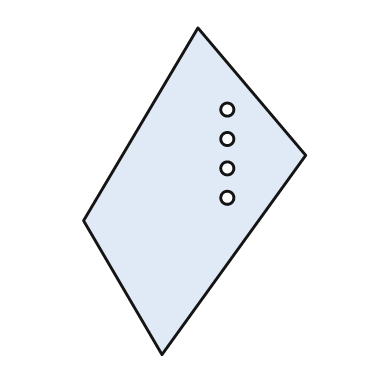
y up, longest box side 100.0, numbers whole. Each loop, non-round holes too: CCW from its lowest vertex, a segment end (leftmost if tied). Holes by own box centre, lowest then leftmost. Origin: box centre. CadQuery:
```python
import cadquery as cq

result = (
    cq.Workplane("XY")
    .moveTo(-10.0, -50.0)
    .lineTo(34.0, 11.0)
    .lineTo(1.0, 50.0)
    .lineTo(-34.0, -9.0)
    .close()
    .moveTo(10.0, -2.0)
    .circle(2.0)
    .moveTo(10.0, 7.0)
    .circle(2.0)
    .moveTo(10.0, 16.0)
    .circle(2.0)
    .moveTo(10.0, 25.0)
    .circle(2.0)
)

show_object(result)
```